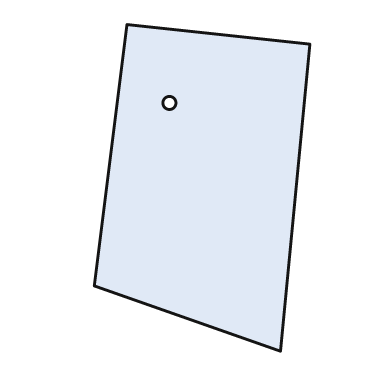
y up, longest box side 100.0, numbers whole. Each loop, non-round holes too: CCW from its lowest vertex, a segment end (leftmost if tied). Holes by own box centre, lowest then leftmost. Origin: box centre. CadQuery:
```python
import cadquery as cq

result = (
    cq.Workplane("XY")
    .moveTo(24.0, -50.0)
    .lineTo(33.0, 44.0)
    .lineTo(-23.0, 50.0)
    .lineTo(-33.0, -30.0)
    .close()
    .moveTo(-10.0, 26.0)
    .circle(2.0)
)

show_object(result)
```